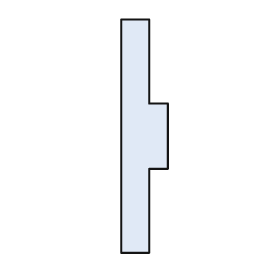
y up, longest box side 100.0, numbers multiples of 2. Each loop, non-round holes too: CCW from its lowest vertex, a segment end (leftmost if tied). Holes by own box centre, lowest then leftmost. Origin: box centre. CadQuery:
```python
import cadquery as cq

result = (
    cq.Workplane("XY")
    .moveTo(-10.0, -50.0)
    .lineTo(2.0, -50.0)
    .lineTo(2.0, -14.0)
    .lineTo(10.0, -14.0)
    .lineTo(10.0, 14.0)
    .lineTo(2.0, 14.0)
    .lineTo(2.0, 50.0)
    .lineTo(-10.0, 50.0)
    .close()
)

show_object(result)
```